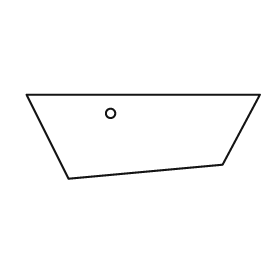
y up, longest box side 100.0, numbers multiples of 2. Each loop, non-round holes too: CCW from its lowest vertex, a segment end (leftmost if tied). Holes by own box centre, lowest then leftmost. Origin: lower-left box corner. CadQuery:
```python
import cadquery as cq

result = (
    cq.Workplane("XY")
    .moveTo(18.0, 0.0)
    .lineTo(84.0, 6.0)
    .lineTo(100.0, 36.0)
    .lineTo(0.0, 36.0)
    .close()
    .moveTo(36.0, 28.0)
    .circle(2.0)
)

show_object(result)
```